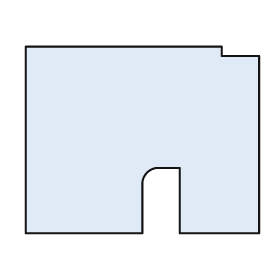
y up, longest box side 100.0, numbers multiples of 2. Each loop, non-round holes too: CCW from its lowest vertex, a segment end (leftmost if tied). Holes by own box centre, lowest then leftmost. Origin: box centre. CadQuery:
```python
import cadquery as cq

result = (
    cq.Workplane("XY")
    .moveTo(-50.0, -40.0)
    .lineTo(0.0, -40.0)
    .lineTo(0.0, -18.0)
    .threePointArc((2.0, -14.0), (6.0, -12.0))
    .lineTo(16.0, -12.0)
    .lineTo(16.0, -40.0)
    .lineTo(50.0, -40.0)
    .lineTo(50.0, 36.0)
    .lineTo(34.0, 36.0)
    .lineTo(34.0, 40.0)
    .lineTo(-50.0, 40.0)
    .close()
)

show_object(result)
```